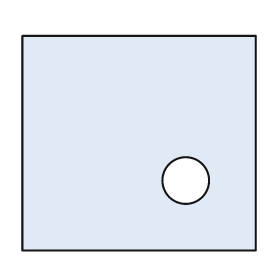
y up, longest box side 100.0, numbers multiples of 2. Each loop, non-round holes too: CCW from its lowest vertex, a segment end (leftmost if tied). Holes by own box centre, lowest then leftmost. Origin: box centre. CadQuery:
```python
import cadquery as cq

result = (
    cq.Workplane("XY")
    .moveTo(-50.0, -46.0)
    .lineTo(50.0, -46.0)
    .lineTo(50.0, 46.0)
    .lineTo(-50.0, 46.0)
    .close()
    .moveTo(20.0, -16.0)
    .circle(10.0)
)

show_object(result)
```